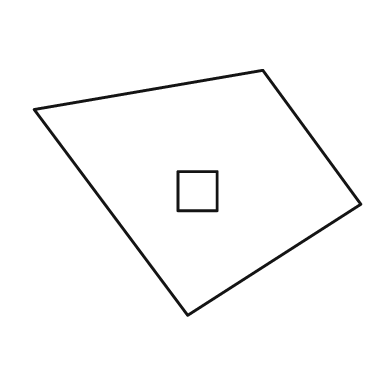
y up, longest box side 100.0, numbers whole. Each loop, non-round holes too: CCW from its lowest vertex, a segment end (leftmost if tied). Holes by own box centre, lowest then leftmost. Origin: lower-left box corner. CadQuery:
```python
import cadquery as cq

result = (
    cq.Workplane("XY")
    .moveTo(47.0, 0.0)
    .lineTo(100.0, 34.0)
    .lineTo(70.0, 75.0)
    .lineTo(0.0, 63.0)
    .close()
    .moveTo(44.0, 32.0)
    .lineTo(56.0, 32.0)
    .lineTo(56.0, 44.0)
    .lineTo(44.0, 44.0)
    .close()
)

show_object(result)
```